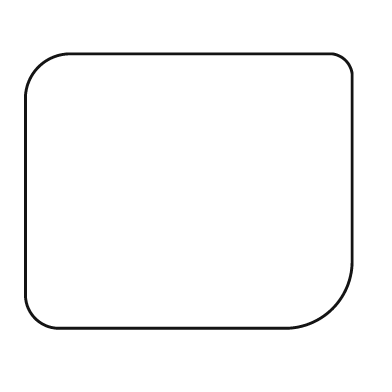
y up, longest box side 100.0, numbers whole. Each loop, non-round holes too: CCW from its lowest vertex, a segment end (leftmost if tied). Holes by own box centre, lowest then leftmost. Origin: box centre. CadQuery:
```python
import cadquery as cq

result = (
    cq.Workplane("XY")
    .moveTo(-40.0, -42.0)
    .lineTo(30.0, -42.0)
    .threePointArc((44.0, -36.0), (50.0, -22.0))
    .lineTo(50.0, 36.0)
    .threePointArc((48.0, 40.0), (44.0, 42.0))
    .lineTo(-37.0, 42.0)
    .threePointArc((-46.0, 38.0), (-50.0, 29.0))
    .lineTo(-50.0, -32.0)
    .threePointArc((-47.0, -39.0), (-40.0, -42.0))
    .close()
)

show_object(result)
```